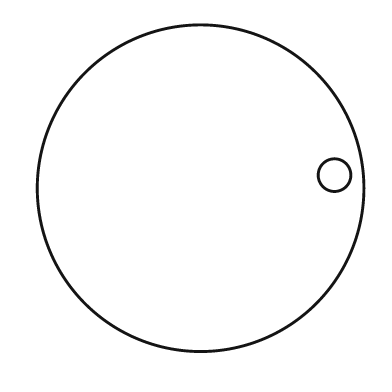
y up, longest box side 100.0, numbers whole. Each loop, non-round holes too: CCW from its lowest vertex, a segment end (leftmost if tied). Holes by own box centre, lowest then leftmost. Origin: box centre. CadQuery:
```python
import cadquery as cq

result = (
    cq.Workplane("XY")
    .moveTo(0.0, 0.0)
    .circle(50.0)
    .moveTo(41.0, 4.0)
    .circle(5.0)
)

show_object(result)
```